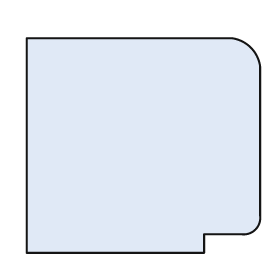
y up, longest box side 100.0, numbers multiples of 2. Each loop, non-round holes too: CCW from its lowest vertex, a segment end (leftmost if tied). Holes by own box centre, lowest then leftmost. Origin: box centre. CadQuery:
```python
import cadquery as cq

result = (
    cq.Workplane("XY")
    .moveTo(-50.0, -46.0)
    .lineTo(26.0, -46.0)
    .lineTo(26.0, -38.0)
    .lineTo(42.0, -38.0)
    .threePointArc((48.0, -36.0), (50.0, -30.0))
    .lineTo(50.0, 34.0)
    .threePointArc((46.0, 42.0), (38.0, 46.0))
    .lineTo(-50.0, 46.0)
    .close()
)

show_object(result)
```